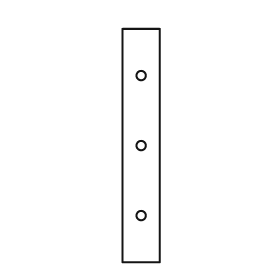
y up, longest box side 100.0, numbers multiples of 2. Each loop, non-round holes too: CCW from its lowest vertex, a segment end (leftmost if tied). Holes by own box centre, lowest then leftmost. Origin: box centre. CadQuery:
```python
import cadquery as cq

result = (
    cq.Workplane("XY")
    .moveTo(-8.0, -50.0)
    .lineTo(8.0, -50.0)
    .lineTo(8.0, 50.0)
    .lineTo(-8.0, 50.0)
    .close()
    .moveTo(0.0, -30.0)
    .circle(2.0)
    .moveTo(0.0, 0.0)
    .circle(2.0)
    .moveTo(0.0, 30.0)
    .circle(2.0)
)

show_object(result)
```